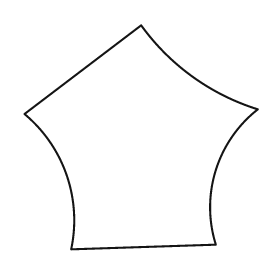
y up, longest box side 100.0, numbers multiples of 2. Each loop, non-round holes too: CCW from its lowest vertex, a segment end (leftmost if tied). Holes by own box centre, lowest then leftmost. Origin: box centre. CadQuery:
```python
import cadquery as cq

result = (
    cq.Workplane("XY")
    .moveTo(-30.0, -48.0)
    .lineTo(32.0, -46.0)
    .threePointArc((32.0, -14.0), (50.0, 12.0))
    .threePointArc((22.0, 26.0), (0.0, 48.0))
    .lineTo(-50.0, 10.0)
    .threePointArc((-32.0, -16.0), (-30.0, -48.0))
    .close()
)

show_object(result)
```